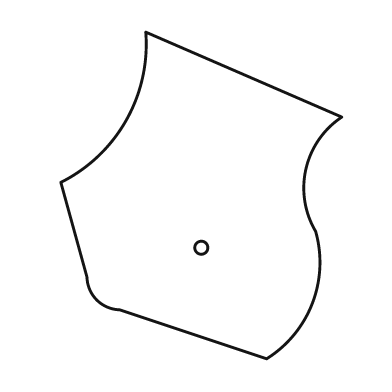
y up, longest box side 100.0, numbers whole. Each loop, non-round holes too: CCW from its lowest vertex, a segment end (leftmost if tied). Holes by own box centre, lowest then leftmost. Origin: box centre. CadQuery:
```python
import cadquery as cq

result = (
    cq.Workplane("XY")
    .moveTo(20.0, -50.0)
    .threePointArc((34.0, -33.0), (35.0, -11.0))
    .threePointArc((32.0, 8.0), (43.0, 24.0))
    .lineTo(-17.0, 50.0)
    .threePointArc((-23.0, 23.0), (-43.0, 4.0))
    .lineTo(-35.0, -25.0)
    .threePointArc((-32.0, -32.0), (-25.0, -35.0))
    .close()
    .moveTo(0.0, -16.0)
    .circle(2.0)
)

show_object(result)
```